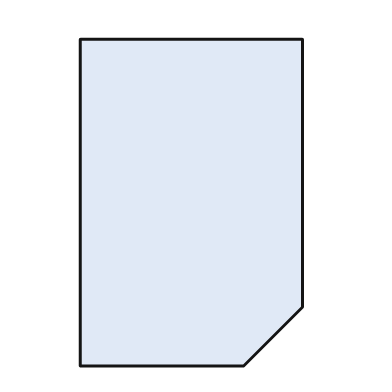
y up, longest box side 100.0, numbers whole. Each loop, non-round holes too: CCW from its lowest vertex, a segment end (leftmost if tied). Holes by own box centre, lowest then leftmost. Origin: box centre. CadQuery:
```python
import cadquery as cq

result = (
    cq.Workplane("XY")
    .moveTo(-34.0, -50.0)
    .lineTo(16.0, -50.0)
    .lineTo(34.0, -32.0)
    .lineTo(34.0, 50.0)
    .lineTo(-34.0, 50.0)
    .close()
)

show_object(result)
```